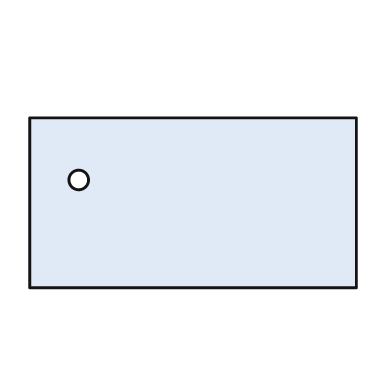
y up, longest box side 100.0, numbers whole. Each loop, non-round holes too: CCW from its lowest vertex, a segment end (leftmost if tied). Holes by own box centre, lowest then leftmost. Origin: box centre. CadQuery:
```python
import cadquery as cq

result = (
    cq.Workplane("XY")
    .moveTo(-50.0, -26.0)
    .lineTo(50.0, -26.0)
    .lineTo(50.0, 26.0)
    .lineTo(-50.0, 26.0)
    .close()
    .moveTo(-35.0, 7.0)
    .circle(3.0)
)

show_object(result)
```